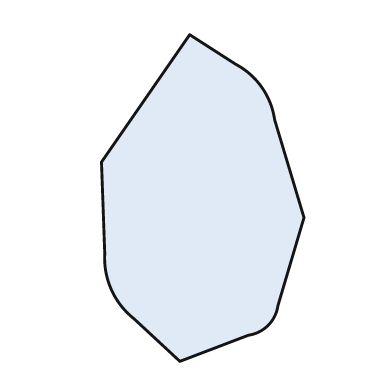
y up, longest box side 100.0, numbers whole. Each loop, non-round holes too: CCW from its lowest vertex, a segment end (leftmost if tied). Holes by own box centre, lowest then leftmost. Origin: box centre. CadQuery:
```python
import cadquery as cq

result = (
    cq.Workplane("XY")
    .moveTo(-7.0, -50.0)
    .lineTo(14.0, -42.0)
    .threePointArc((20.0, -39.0), (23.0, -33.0))
    .lineTo(31.0, -6.0)
    .lineTo(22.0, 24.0)
    .threePointArc((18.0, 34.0), (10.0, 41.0))
    .lineTo(-4.0, 50.0)
    .lineTo(-31.0, 11.0)
    .lineTo(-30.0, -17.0)
    .threePointArc((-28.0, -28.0), (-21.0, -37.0))
    .close()
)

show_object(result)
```